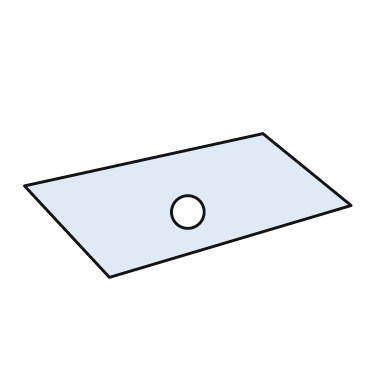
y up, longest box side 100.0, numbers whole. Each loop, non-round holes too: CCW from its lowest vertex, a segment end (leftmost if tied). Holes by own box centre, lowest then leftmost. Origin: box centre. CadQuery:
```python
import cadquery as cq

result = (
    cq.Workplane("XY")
    .moveTo(-24.0, -22.0)
    .lineTo(50.0, 0.0)
    .lineTo(23.0, 22.0)
    .lineTo(-50.0, 6.0)
    .close()
    .moveTo(0.0, -2.0)
    .circle(5.0)
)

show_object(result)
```